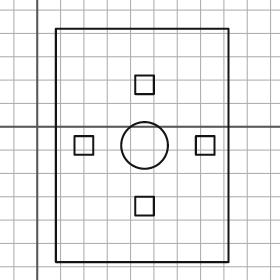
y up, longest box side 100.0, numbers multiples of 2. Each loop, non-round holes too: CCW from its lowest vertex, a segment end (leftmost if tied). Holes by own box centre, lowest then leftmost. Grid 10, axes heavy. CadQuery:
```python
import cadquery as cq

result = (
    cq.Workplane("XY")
    .moveTo(8.0, -58.0)
    .lineTo(82.0, -58.0)
    .lineTo(82.0, 42.0)
    .lineTo(8.0, 42.0)
    .close()
    .moveTo(42.0, -38.0)
    .lineTo(50.0, -38.0)
    .lineTo(50.0, -30.0)
    .lineTo(42.0, -30.0)
    .close()
    .moveTo(16.0, -12.0)
    .lineTo(24.0, -12.0)
    .lineTo(24.0, -4.0)
    .lineTo(16.0, -4.0)
    .close()
    .moveTo(46.0, -8.0)
    .circle(10.0)
    .moveTo(68.0, -12.0)
    .lineTo(76.0, -12.0)
    .lineTo(76.0, -4.0)
    .lineTo(68.0, -4.0)
    .close()
    .moveTo(42.0, 14.0)
    .lineTo(50.0, 14.0)
    .lineTo(50.0, 22.0)
    .lineTo(42.0, 22.0)
    .close()
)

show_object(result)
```